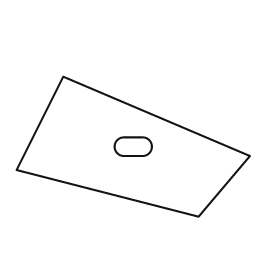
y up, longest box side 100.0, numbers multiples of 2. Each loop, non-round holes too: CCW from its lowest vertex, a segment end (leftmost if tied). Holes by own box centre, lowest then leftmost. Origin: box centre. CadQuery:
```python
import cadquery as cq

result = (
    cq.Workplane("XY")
    .moveTo(28.0, -30.0)
    .lineTo(50.0, -4.0)
    .lineTo(-30.0, 30.0)
    .lineTo(-50.0, -10.0)
    .close()
    .moveTo(-4.0, -4.0)
    .lineTo(4.0, -4.0)
    .threePointArc((8.0, 0.0), (4.0, 4.0))
    .lineTo(-4.0, 4.0)
    .threePointArc((-8.0, 0.0), (-4.0, -4.0))
    .close()
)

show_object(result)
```